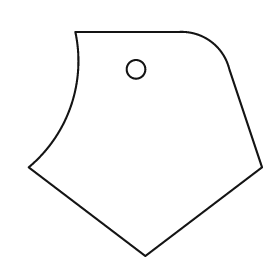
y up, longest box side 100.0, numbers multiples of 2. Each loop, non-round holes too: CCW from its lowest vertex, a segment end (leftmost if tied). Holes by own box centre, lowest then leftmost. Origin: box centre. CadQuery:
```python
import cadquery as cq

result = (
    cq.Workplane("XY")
    .moveTo(0.0, -48.0)
    .lineTo(50.0, -10.0)
    .lineTo(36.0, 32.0)
    .threePointArc((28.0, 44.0), (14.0, 48.0))
    .lineTo(-30.0, 48.0)
    .threePointArc((-32.0, 16.0), (-50.0, -10.0))
    .close()
    .moveTo(-4.0, 32.0)
    .circle(4.0)
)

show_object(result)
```